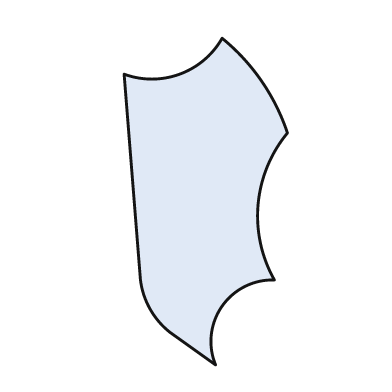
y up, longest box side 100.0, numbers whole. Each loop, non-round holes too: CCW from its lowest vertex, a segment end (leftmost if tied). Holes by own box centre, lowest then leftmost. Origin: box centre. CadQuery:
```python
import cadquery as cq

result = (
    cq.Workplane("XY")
    .moveTo(3.0, -50.0)
    .threePointArc((5.0, -32.0), (21.0, -24.0))
    .threePointArc((16.0, -1.0), (25.0, 21.0))
    .threePointArc((17.0, 37.0), (5.0, 50.0))
    .threePointArc((-8.0, 39.0), (-25.0, 39.0))
    .lineTo(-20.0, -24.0)
    .threePointArc((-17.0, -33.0), (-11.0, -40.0))
    .close()
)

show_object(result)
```